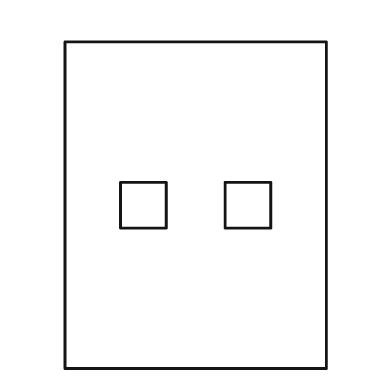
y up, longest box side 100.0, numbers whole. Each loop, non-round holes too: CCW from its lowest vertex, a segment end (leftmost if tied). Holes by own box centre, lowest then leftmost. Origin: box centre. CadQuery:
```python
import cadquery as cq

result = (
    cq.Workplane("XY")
    .moveTo(-40.0, -50.0)
    .lineTo(40.0, -50.0)
    .lineTo(40.0, 50.0)
    .lineTo(-40.0, 50.0)
    .close()
    .moveTo(-23.0, -7.0)
    .lineTo(-9.0, -7.0)
    .lineTo(-9.0, 7.0)
    .lineTo(-23.0, 7.0)
    .close()
    .moveTo(9.0, -7.0)
    .lineTo(23.0, -7.0)
    .lineTo(23.0, 7.0)
    .lineTo(9.0, 7.0)
    .close()
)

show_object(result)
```